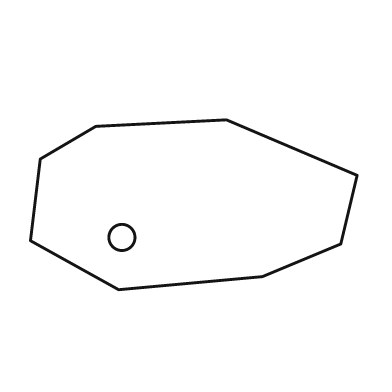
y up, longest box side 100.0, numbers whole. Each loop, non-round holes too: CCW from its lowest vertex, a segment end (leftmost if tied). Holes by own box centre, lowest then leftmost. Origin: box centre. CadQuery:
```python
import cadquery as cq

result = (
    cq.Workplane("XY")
    .moveTo(-23.0, -26.0)
    .lineTo(21.0, -22.0)
    .lineTo(45.0, -12.0)
    .lineTo(50.0, 9.0)
    .lineTo(10.0, 26.0)
    .lineTo(-30.0, 24.0)
    .lineTo(-47.0, 14.0)
    .lineTo(-50.0, -11.0)
    .close()
    .moveTo(-22.0, -10.0)
    .circle(4.0)
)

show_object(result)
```